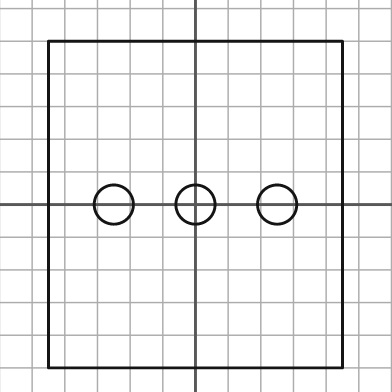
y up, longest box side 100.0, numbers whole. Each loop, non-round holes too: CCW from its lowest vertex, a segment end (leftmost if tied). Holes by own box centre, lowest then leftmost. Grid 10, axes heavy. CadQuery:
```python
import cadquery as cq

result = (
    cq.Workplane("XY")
    .moveTo(-45.0, -50.0)
    .lineTo(45.0, -50.0)
    .lineTo(45.0, 50.0)
    .lineTo(-45.0, 50.0)
    .close()
    .moveTo(-25.0, 0.0)
    .circle(6.0)
    .moveTo(0.0, 0.0)
    .circle(6.0)
    .moveTo(25.0, 0.0)
    .circle(6.0)
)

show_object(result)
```